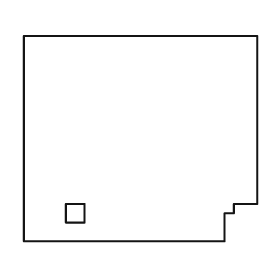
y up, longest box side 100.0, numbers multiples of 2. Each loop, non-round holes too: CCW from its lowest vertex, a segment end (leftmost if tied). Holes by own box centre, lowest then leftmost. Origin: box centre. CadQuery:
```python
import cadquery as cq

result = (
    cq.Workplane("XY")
    .moveTo(-50.0, -44.0)
    .lineTo(36.0, -44.0)
    .lineTo(36.0, -32.0)
    .lineTo(40.0, -32.0)
    .lineTo(40.0, -28.0)
    .lineTo(50.0, -28.0)
    .lineTo(50.0, 44.0)
    .lineTo(-50.0, 44.0)
    .close()
    .moveTo(-32.0, -36.0)
    .lineTo(-24.0, -36.0)
    .lineTo(-24.0, -28.0)
    .lineTo(-32.0, -28.0)
    .close()
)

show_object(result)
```